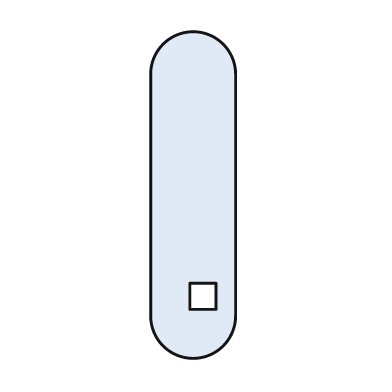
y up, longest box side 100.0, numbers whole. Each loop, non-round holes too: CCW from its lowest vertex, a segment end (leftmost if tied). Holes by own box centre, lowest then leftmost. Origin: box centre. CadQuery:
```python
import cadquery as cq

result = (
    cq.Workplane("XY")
    .moveTo(-13.0, -37.0)
    .threePointArc((0.0, -50.0), (13.0, -37.0))
    .lineTo(13.0, 37.0)
    .threePointArc((0.0, 50.0), (-13.0, 37.0))
    .close()
    .moveTo(-1.0, -35.0)
    .lineTo(7.0, -35.0)
    .lineTo(7.0, -27.0)
    .lineTo(-1.0, -27.0)
    .close()
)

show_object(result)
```